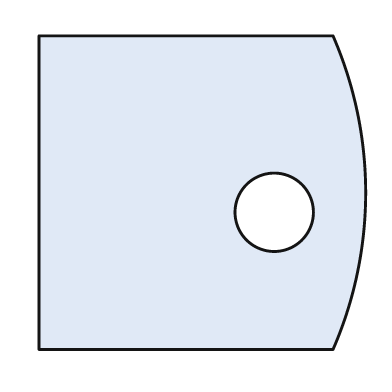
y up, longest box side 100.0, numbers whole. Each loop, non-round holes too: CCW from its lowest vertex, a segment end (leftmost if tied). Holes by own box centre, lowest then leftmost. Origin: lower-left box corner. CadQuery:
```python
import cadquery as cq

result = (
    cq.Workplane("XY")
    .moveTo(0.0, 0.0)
    .lineTo(90.0, 0.0)
    .threePointArc((100.0, 48.0), (90.0, 96.0))
    .lineTo(0.0, 96.0)
    .close()
    .moveTo(72.0, 42.0)
    .circle(12.0)
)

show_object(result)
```